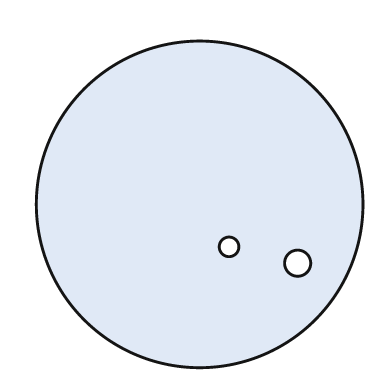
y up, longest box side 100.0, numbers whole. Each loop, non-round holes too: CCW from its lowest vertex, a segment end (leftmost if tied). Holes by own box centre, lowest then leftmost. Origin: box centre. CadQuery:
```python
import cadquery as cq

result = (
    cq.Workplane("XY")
    .moveTo(0.0, 0.0)
    .circle(50.0)
    .moveTo(30.0, -18.0)
    .circle(4.0)
    .moveTo(9.0, -13.0)
    .circle(3.0)
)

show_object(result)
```